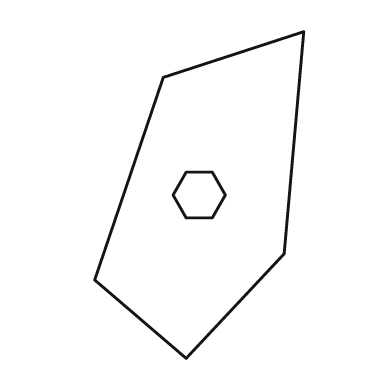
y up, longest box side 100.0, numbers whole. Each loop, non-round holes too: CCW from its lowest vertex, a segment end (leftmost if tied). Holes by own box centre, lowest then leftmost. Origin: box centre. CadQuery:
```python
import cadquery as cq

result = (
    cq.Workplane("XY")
    .moveTo(-4.0, -50.0)
    .lineTo(26.0, -18.0)
    .lineTo(32.0, 50.0)
    .lineTo(-11.0, 36.0)
    .lineTo(-32.0, -26.0)
    .close()
    .moveTo(-4.0, -7.0)
    .lineTo(4.0, -7.0)
    .lineTo(8.0, 0.0)
    .lineTo(4.0, 7.0)
    .lineTo(-4.0, 7.0)
    .lineTo(-8.0, 0.0)
    .close()
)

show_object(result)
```